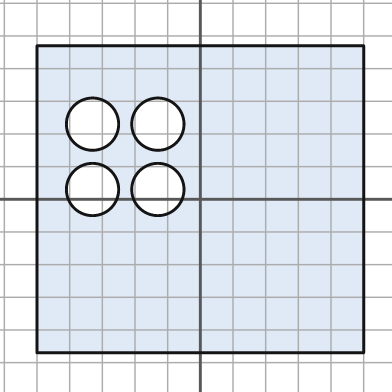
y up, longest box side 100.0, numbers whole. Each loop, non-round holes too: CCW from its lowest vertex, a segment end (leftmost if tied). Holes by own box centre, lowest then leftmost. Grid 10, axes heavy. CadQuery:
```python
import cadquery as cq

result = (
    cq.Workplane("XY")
    .moveTo(-50.0, -47.0)
    .lineTo(50.0, -47.0)
    .lineTo(50.0, 47.0)
    .lineTo(-50.0, 47.0)
    .close()
    .moveTo(-33.0, 3.0)
    .circle(8.0)
    .moveTo(-13.0, 3.0)
    .circle(8.0)
    .moveTo(-33.0, 23.0)
    .circle(8.0)
    .moveTo(-13.0, 23.0)
    .circle(8.0)
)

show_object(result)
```